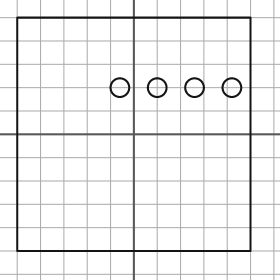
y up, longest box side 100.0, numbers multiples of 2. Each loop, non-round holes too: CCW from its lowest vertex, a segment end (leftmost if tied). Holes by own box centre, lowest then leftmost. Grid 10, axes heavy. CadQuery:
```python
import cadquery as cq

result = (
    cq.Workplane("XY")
    .moveTo(-50.0, -50.0)
    .lineTo(50.0, -50.0)
    .lineTo(50.0, 50.0)
    .lineTo(-50.0, 50.0)
    .close()
    .moveTo(-6.0, 20.0)
    .circle(4.0)
    .moveTo(10.0, 20.0)
    .circle(4.0)
    .moveTo(26.0, 20.0)
    .circle(4.0)
    .moveTo(42.0, 20.0)
    .circle(4.0)
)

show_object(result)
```